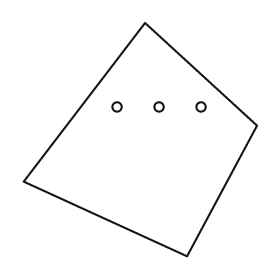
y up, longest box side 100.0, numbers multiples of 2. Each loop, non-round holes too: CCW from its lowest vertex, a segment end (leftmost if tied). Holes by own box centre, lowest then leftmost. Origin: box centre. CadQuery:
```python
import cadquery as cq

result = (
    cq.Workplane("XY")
    .moveTo(20.0, -50.0)
    .lineTo(50.0, 6.0)
    .lineTo(2.0, 50.0)
    .lineTo(-50.0, -18.0)
    .close()
    .moveTo(-10.0, 14.0)
    .circle(2.0)
    .moveTo(8.0, 14.0)
    .circle(2.0)
    .moveTo(26.0, 14.0)
    .circle(2.0)
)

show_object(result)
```